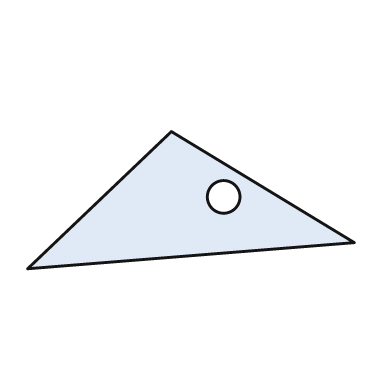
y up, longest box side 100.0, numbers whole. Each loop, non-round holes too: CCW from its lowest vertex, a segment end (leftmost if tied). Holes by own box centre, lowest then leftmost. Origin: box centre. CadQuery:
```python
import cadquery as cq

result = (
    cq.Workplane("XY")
    .moveTo(-50.0, -21.0)
    .lineTo(50.0, -13.0)
    .lineTo(-6.0, 21.0)
    .close()
    .moveTo(10.0, 1.0)
    .circle(5.0)
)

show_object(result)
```